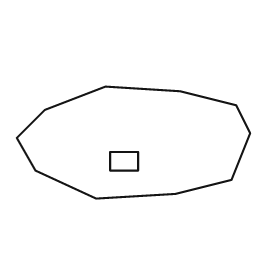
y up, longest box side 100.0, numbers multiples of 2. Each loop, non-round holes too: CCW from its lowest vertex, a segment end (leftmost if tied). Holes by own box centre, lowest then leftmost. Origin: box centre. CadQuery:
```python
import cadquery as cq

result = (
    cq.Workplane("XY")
    .moveTo(-16.0, -24.0)
    .lineTo(18.0, -22.0)
    .lineTo(42.0, -16.0)
    .lineTo(50.0, 4.0)
    .lineTo(44.0, 16.0)
    .lineTo(20.0, 22.0)
    .lineTo(-12.0, 24.0)
    .lineTo(-38.0, 14.0)
    .lineTo(-50.0, 2.0)
    .lineTo(-42.0, -12.0)
    .close()
    .moveTo(-10.0, -12.0)
    .lineTo(2.0, -12.0)
    .lineTo(2.0, -4.0)
    .lineTo(-10.0, -4.0)
    .close()
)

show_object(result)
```